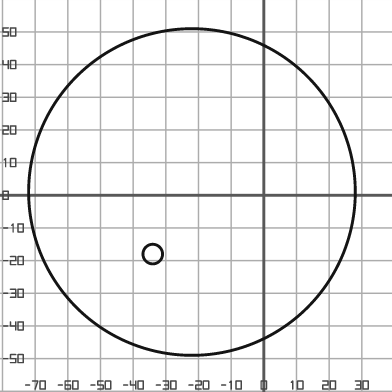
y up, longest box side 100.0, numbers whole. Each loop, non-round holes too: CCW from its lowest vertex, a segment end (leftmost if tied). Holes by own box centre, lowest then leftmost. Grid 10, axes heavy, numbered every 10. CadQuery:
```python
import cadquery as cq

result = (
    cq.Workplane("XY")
    .moveTo(-22.0, 1.0)
    .circle(50.0)
    .moveTo(-34.0, -18.0)
    .circle(3.0)
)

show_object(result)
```